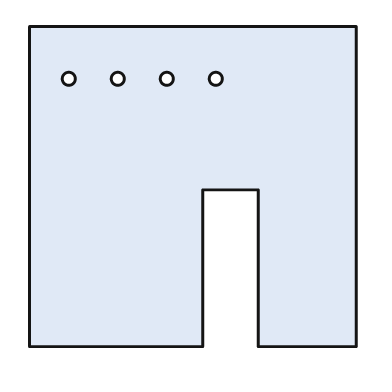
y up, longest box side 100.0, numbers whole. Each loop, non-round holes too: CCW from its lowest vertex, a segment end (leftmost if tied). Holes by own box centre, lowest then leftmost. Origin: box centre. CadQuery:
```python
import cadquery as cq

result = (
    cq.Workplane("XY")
    .moveTo(-50.0, -49.0)
    .lineTo(3.0, -49.0)
    .lineTo(3.0, -1.0)
    .lineTo(20.0, -1.0)
    .lineTo(20.0, -49.0)
    .lineTo(50.0, -49.0)
    .lineTo(50.0, 49.0)
    .lineTo(-50.0, 49.0)
    .close()
    .moveTo(-38.0, 33.0)
    .circle(2.0)
    .moveTo(-23.0, 33.0)
    .circle(2.0)
    .moveTo(-8.0, 33.0)
    .circle(2.0)
    .moveTo(7.0, 33.0)
    .circle(2.0)
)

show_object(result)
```